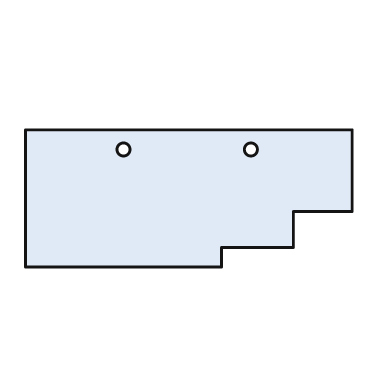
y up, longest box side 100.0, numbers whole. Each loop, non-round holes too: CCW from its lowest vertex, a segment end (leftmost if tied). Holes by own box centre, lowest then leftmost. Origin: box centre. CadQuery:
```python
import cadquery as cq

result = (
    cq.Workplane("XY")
    .moveTo(-50.0, -21.0)
    .lineTo(10.0, -21.0)
    .lineTo(10.0, -15.0)
    .lineTo(32.0, -15.0)
    .lineTo(32.0, -4.0)
    .lineTo(50.0, -4.0)
    .lineTo(50.0, 21.0)
    .lineTo(-50.0, 21.0)
    .close()
    .moveTo(-20.0, 15.0)
    .circle(2.0)
    .moveTo(19.0, 15.0)
    .circle(2.0)
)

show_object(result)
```